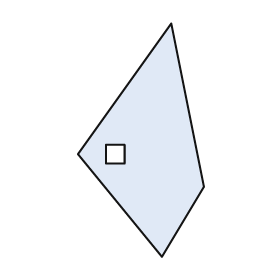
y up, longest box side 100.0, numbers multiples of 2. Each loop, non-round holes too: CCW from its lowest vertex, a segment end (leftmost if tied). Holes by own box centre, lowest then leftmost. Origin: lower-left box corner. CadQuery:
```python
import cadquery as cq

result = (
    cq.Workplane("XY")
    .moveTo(36.0, 0.0)
    .lineTo(54.0, 30.0)
    .lineTo(40.0, 100.0)
    .lineTo(0.0, 44.0)
    .close()
    .moveTo(12.0, 40.0)
    .lineTo(20.0, 40.0)
    .lineTo(20.0, 48.0)
    .lineTo(12.0, 48.0)
    .close()
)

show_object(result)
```